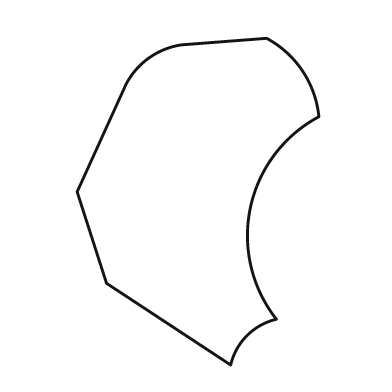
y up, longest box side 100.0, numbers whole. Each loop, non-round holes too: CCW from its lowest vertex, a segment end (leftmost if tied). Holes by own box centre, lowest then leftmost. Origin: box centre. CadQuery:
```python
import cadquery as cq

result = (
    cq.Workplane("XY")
    .moveTo(10.0, -50.0)
    .threePointArc((15.0, -41.0), (24.0, -36.0))
    .threePointArc((16.0, -2.0), (37.0, 26.0))
    .threePointArc((32.0, 40.0), (21.0, 50.0))
    .lineTo(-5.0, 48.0)
    .threePointArc((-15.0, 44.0), (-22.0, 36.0))
    .lineTo(-37.0, 3.0)
    .lineTo(-28.0, -25.0)
    .close()
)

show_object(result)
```